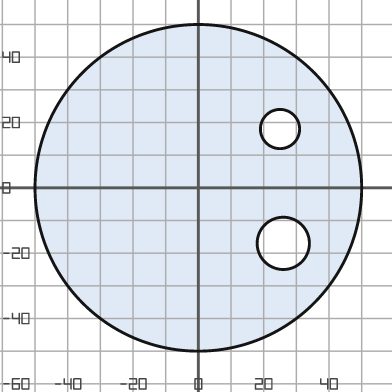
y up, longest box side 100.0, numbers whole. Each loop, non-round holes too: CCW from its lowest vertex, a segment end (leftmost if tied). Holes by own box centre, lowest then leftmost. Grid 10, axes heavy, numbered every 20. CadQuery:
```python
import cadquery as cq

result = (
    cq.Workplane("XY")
    .moveTo(0.0, 0.0)
    .circle(50.0)
    .moveTo(26.0, -17.0)
    .circle(8.0)
    .moveTo(25.0, 18.0)
    .circle(6.0)
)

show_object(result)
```